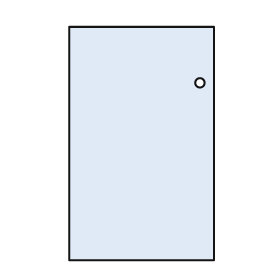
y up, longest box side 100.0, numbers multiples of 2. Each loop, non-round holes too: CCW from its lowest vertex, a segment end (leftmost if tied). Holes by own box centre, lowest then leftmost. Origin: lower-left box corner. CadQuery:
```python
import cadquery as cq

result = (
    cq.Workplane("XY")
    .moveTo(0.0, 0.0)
    .lineTo(62.0, 0.0)
    .lineTo(62.0, 100.0)
    .lineTo(0.0, 100.0)
    .close()
    .moveTo(56.0, 76.0)
    .circle(2.0)
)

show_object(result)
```